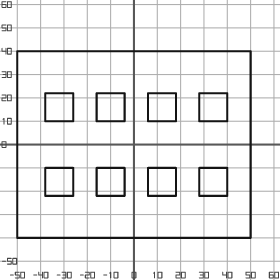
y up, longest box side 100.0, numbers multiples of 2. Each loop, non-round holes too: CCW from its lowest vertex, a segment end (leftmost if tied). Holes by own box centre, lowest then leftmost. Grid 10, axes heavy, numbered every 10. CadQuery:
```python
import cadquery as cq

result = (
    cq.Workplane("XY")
    .moveTo(-50.0, -40.0)
    .lineTo(50.0, -40.0)
    .lineTo(50.0, 40.0)
    .lineTo(-50.0, 40.0)
    .close()
    .moveTo(-38.0, -22.0)
    .lineTo(-26.0, -22.0)
    .lineTo(-26.0, -10.0)
    .lineTo(-38.0, -10.0)
    .close()
    .moveTo(-16.0, -22.0)
    .lineTo(-4.0, -22.0)
    .lineTo(-4.0, -10.0)
    .lineTo(-16.0, -10.0)
    .close()
    .moveTo(6.0, -22.0)
    .lineTo(18.0, -22.0)
    .lineTo(18.0, -10.0)
    .lineTo(6.0, -10.0)
    .close()
    .moveTo(28.0, -22.0)
    .lineTo(40.0, -22.0)
    .lineTo(40.0, -10.0)
    .lineTo(28.0, -10.0)
    .close()
    .moveTo(-38.0, 10.0)
    .lineTo(-26.0, 10.0)
    .lineTo(-26.0, 22.0)
    .lineTo(-38.0, 22.0)
    .close()
    .moveTo(-16.0, 10.0)
    .lineTo(-4.0, 10.0)
    .lineTo(-4.0, 22.0)
    .lineTo(-16.0, 22.0)
    .close()
    .moveTo(6.0, 10.0)
    .lineTo(18.0, 10.0)
    .lineTo(18.0, 22.0)
    .lineTo(6.0, 22.0)
    .close()
    .moveTo(28.0, 10.0)
    .lineTo(40.0, 10.0)
    .lineTo(40.0, 22.0)
    .lineTo(28.0, 22.0)
    .close()
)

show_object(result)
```